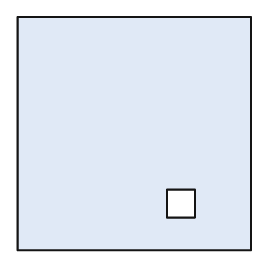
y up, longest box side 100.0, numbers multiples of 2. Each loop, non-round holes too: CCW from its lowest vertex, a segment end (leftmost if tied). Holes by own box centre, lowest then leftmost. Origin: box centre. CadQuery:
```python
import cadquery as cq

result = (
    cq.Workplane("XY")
    .moveTo(-50.0, -50.0)
    .lineTo(50.0, -50.0)
    .lineTo(50.0, 50.0)
    .lineTo(-50.0, 50.0)
    .close()
    .moveTo(14.0, -36.0)
    .lineTo(26.0, -36.0)
    .lineTo(26.0, -24.0)
    .lineTo(14.0, -24.0)
    .close()
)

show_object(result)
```